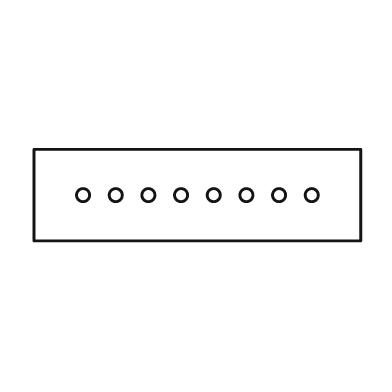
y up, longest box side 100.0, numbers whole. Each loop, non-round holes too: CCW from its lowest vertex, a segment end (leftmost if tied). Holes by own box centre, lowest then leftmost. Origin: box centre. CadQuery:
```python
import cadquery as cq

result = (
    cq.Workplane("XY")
    .moveTo(-50.0, -14.0)
    .lineTo(50.0, -14.0)
    .lineTo(50.0, 14.0)
    .lineTo(-50.0, 14.0)
    .close()
    .moveTo(-35.0, 0.0)
    .circle(2.0)
    .moveTo(-25.0, 0.0)
    .circle(2.0)
    .moveTo(-15.0, 0.0)
    .circle(2.0)
    .moveTo(-5.0, 0.0)
    .circle(2.0)
    .moveTo(5.0, 0.0)
    .circle(2.0)
    .moveTo(15.0, 0.0)
    .circle(2.0)
    .moveTo(25.0, 0.0)
    .circle(2.0)
    .moveTo(35.0, 0.0)
    .circle(2.0)
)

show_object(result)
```